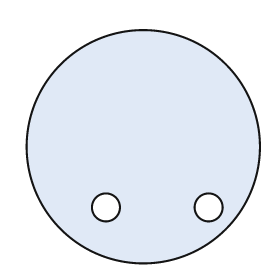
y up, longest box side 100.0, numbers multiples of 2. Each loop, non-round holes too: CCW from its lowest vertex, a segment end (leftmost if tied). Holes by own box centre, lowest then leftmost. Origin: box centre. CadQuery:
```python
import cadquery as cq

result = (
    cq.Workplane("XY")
    .moveTo(0.0, 0.0)
    .circle(50.0)
    .moveTo(-16.0, -26.0)
    .circle(6.0)
    .moveTo(28.0, -26.0)
    .circle(6.0)
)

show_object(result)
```